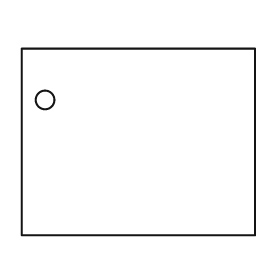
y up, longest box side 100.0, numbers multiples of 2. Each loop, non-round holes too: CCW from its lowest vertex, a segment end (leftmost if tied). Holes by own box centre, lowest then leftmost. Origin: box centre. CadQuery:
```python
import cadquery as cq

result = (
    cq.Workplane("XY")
    .moveTo(-50.0, -40.0)
    .lineTo(50.0, -40.0)
    .lineTo(50.0, 40.0)
    .lineTo(-50.0, 40.0)
    .close()
    .moveTo(-40.0, 18.0)
    .circle(4.0)
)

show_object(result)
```